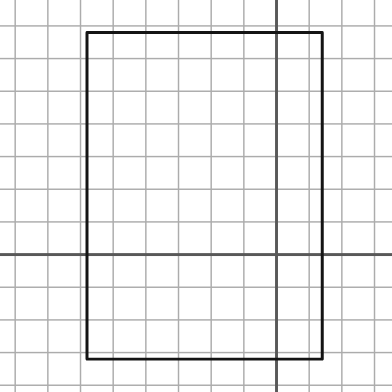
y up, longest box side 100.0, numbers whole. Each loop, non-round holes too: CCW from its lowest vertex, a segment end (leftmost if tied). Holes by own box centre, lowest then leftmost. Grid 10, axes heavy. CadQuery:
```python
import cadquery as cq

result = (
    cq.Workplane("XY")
    .moveTo(-58.0, -32.0)
    .lineTo(14.0, -32.0)
    .lineTo(14.0, 68.0)
    .lineTo(-58.0, 68.0)
    .close()
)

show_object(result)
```